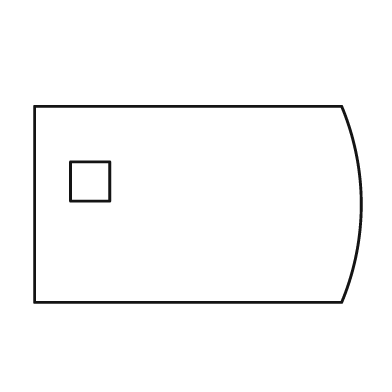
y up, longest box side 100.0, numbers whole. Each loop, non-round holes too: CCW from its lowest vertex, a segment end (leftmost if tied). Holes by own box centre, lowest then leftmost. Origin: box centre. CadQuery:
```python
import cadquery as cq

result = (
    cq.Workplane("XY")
    .moveTo(-50.0, -30.0)
    .lineTo(44.0, -30.0)
    .threePointArc((50.0, 0.0), (44.0, 30.0))
    .lineTo(-50.0, 30.0)
    .close()
    .moveTo(-39.0, 1.0)
    .lineTo(-27.0, 1.0)
    .lineTo(-27.0, 13.0)
    .lineTo(-39.0, 13.0)
    .close()
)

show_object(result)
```